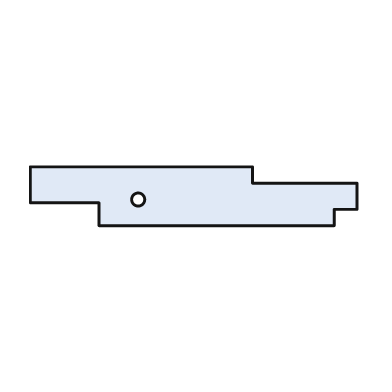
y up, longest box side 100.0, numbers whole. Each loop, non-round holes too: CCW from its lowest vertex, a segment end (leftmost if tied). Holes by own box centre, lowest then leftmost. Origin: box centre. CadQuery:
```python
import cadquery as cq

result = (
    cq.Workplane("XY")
    .moveTo(-29.0, -9.0)
    .lineTo(43.0, -9.0)
    .lineTo(43.0, -4.0)
    .lineTo(50.0, -4.0)
    .lineTo(50.0, 4.0)
    .lineTo(18.0, 4.0)
    .lineTo(18.0, 9.0)
    .lineTo(-50.0, 9.0)
    .lineTo(-50.0, -2.0)
    .lineTo(-29.0, -2.0)
    .close()
    .moveTo(-17.0, -1.0)
    .circle(2.0)
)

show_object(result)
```